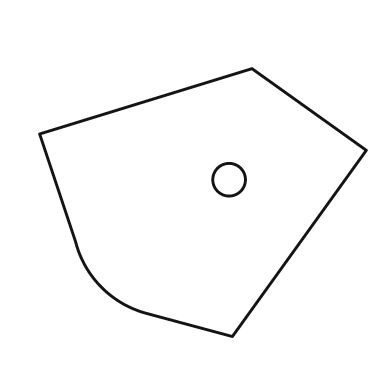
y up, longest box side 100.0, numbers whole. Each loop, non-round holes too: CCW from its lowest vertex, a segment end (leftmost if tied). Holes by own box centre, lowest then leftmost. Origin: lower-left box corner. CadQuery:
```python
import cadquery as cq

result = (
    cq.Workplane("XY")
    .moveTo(59.0, 0.0)
    .lineTo(100.0, 57.0)
    .lineTo(65.0, 82.0)
    .lineTo(0.0, 62.0)
    .lineTo(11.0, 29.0)
    .threePointArc((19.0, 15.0), (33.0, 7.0))
    .close()
    .moveTo(58.0, 48.0)
    .circle(5.0)
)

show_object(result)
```